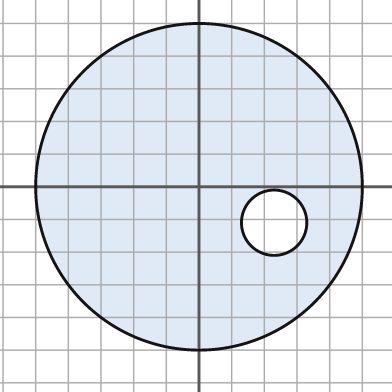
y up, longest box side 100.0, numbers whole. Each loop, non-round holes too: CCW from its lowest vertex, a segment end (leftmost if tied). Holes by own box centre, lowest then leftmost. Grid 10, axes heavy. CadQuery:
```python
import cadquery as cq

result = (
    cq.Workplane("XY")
    .moveTo(0.0, 0.0)
    .circle(50.0)
    .moveTo(23.0, -11.0)
    .circle(10.0)
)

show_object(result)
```